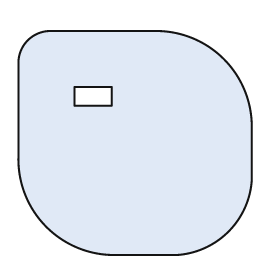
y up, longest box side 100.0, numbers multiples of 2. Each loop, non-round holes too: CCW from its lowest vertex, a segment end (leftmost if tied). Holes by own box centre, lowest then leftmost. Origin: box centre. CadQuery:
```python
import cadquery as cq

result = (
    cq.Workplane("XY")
    .moveTo(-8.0, -48.0)
    .lineTo(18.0, -48.0)
    .threePointArc((40.0, -38.0), (50.0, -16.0))
    .lineTo(50.0, 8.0)
    .threePointArc((38.0, 36.0), (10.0, 48.0))
    .lineTo(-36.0, 48.0)
    .threePointArc((-46.0, 44.0), (-50.0, 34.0))
    .lineTo(-50.0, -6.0)
    .threePointArc((-38.0, -36.0), (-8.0, -48.0))
    .close()
    .moveTo(-26.0, 16.0)
    .lineTo(-10.0, 16.0)
    .lineTo(-10.0, 24.0)
    .lineTo(-26.0, 24.0)
    .close()
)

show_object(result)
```